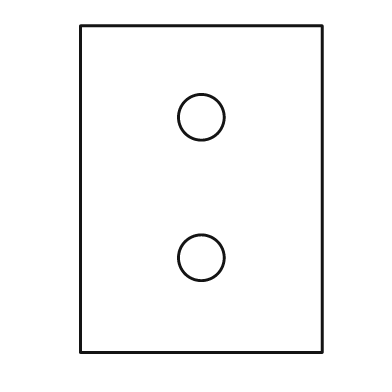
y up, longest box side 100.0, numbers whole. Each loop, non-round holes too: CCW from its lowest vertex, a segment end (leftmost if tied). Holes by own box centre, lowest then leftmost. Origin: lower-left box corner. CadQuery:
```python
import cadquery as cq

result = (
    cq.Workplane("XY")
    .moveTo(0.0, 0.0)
    .lineTo(74.0, 0.0)
    .lineTo(74.0, 100.0)
    .lineTo(0.0, 100.0)
    .close()
    .moveTo(37.0, 29.0)
    .circle(7.0)
    .moveTo(37.0, 72.0)
    .circle(7.0)
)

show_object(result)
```